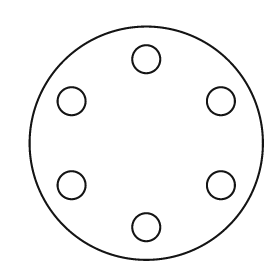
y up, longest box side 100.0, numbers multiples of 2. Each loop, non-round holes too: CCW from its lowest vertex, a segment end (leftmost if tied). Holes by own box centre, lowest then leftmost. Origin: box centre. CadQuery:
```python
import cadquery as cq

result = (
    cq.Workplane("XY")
    .moveTo(0.0, 0.0)
    .circle(50.0)
    .moveTo(0.0, -36.0)
    .circle(6.0)
    .moveTo(-32.0, -18.0)
    .circle(6.0)
    .moveTo(32.0, -18.0)
    .circle(6.0)
    .moveTo(-32.0, 18.0)
    .circle(6.0)
    .moveTo(32.0, 18.0)
    .circle(6.0)
    .moveTo(0.0, 36.0)
    .circle(6.0)
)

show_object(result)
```